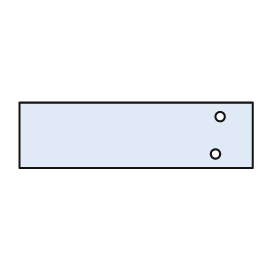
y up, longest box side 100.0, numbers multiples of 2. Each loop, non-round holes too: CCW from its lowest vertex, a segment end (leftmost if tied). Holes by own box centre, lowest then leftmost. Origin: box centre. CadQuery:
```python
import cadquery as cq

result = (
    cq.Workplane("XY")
    .moveTo(-50.0, -14.0)
    .lineTo(50.0, -14.0)
    .lineTo(50.0, 14.0)
    .lineTo(-50.0, 14.0)
    .close()
    .moveTo(34.0, -8.0)
    .circle(2.0)
    .moveTo(36.0, 8.0)
    .circle(2.0)
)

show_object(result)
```